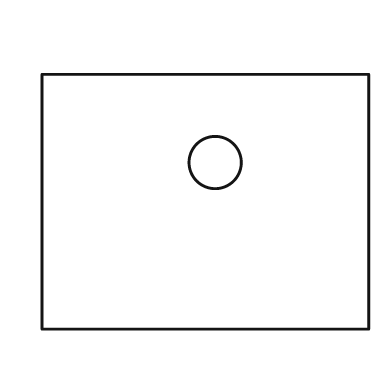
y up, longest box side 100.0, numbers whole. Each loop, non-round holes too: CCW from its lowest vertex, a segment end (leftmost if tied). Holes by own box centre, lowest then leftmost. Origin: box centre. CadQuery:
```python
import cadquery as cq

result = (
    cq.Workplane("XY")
    .moveTo(-50.0, -39.0)
    .lineTo(50.0, -39.0)
    .lineTo(50.0, 39.0)
    .lineTo(-50.0, 39.0)
    .close()
    .moveTo(3.0, 12.0)
    .circle(8.0)
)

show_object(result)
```